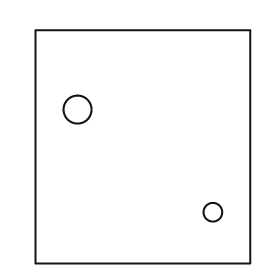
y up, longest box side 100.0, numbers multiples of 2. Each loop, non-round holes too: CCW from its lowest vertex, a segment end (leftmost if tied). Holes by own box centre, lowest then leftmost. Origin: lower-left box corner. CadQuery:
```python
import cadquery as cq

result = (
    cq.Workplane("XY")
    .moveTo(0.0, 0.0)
    .lineTo(92.0, 0.0)
    .lineTo(92.0, 100.0)
    .lineTo(0.0, 100.0)
    .close()
    .moveTo(76.0, 22.0)
    .circle(4.0)
    .moveTo(18.0, 66.0)
    .circle(6.0)
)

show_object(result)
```